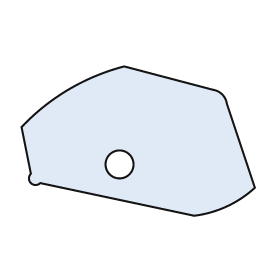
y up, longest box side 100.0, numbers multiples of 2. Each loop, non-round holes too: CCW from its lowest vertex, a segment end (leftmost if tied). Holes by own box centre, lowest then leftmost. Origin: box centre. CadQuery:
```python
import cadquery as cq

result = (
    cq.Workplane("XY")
    .moveTo(24.0, -32.0)
    .threePointArc((38.0, -28.0), (50.0, -20.0))
    .lineTo(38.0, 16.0)
    .threePointArc((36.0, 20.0), (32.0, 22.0))
    .lineTo(-6.0, 32.0)
    .threePointArc((-30.0, 22.0), (-50.0, 6.0))
    .lineTo(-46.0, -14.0)
    .threePointArc((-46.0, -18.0), (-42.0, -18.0))
    .close()
    .moveTo(-8.0, -10.0)
    .circle(6.0)
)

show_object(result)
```